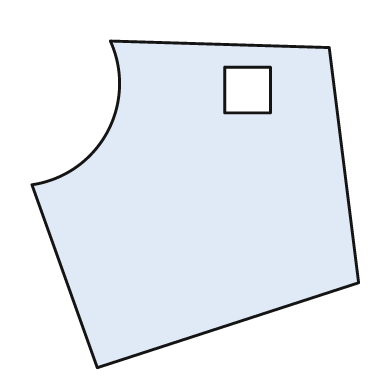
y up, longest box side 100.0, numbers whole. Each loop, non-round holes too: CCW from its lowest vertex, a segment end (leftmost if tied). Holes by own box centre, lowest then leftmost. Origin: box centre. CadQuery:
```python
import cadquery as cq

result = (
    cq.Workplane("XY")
    .moveTo(-30.0, -50.0)
    .lineTo(50.0, -24.0)
    .lineTo(41.0, 48.0)
    .lineTo(-26.0, 50.0)
    .threePointArc((-27.0, 22.0), (-50.0, 6.0))
    .close()
    .moveTo(9.0, 28.0)
    .lineTo(23.0, 28.0)
    .lineTo(23.0, 42.0)
    .lineTo(9.0, 42.0)
    .close()
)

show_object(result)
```